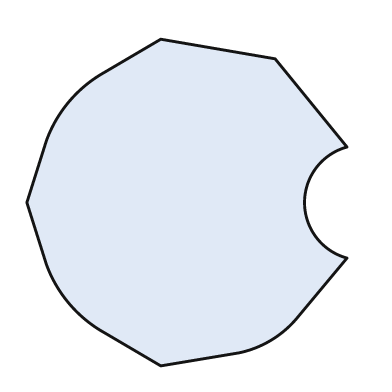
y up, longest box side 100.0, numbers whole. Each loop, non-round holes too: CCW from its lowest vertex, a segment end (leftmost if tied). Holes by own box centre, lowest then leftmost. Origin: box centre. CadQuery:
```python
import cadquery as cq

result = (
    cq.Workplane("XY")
    .moveTo(-8.0, -50.0)
    .lineTo(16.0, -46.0)
    .threePointArc((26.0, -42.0), (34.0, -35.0))
    .lineTo(49.0, -17.0)
    .threePointArc((36.0, 0.0), (49.0, 17.0))
    .lineTo(27.0, 44.0)
    .lineTo(-8.0, 50.0)
    .lineTo(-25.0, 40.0)
    .threePointArc((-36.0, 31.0), (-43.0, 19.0))
    .lineTo(-49.0, 0.0)
    .lineTo(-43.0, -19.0)
    .threePointArc((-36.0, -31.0), (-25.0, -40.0))
    .close()
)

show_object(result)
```